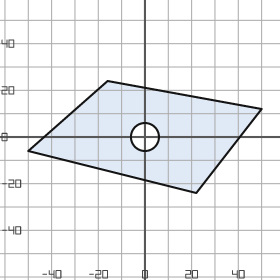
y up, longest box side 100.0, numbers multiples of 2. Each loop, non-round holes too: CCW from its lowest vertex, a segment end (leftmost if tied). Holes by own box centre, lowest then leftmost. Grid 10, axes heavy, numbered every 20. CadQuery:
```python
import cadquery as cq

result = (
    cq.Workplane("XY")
    .moveTo(22.0, -24.0)
    .lineTo(50.0, 12.0)
    .lineTo(-16.0, 24.0)
    .lineTo(-50.0, -6.0)
    .close()
    .moveTo(0.0, 0.0)
    .circle(6.0)
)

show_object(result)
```